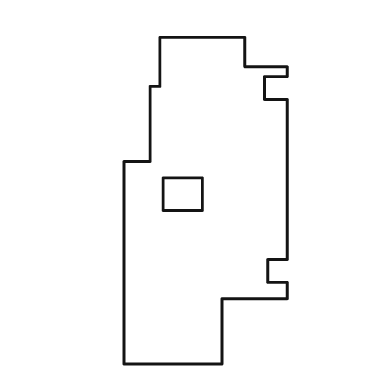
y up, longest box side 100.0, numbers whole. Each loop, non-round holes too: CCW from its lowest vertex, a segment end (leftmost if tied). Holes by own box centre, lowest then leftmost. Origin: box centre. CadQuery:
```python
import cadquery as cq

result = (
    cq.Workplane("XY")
    .moveTo(-25.0, -50.0)
    .lineTo(5.0, -50.0)
    .lineTo(5.0, -30.0)
    .lineTo(25.0, -30.0)
    .lineTo(25.0, -25.0)
    .lineTo(19.0, -25.0)
    .lineTo(19.0, -18.0)
    .lineTo(25.0, -18.0)
    .lineTo(25.0, 31.0)
    .lineTo(18.0, 31.0)
    .lineTo(18.0, 38.0)
    .lineTo(25.0, 38.0)
    .lineTo(25.0, 41.0)
    .lineTo(12.0, 41.0)
    .lineTo(12.0, 50.0)
    .lineTo(-14.0, 50.0)
    .lineTo(-14.0, 35.0)
    .lineTo(-17.0, 35.0)
    .lineTo(-17.0, 12.0)
    .lineTo(-25.0, 12.0)
    .close()
    .moveTo(-13.0, -3.0)
    .lineTo(-1.0, -3.0)
    .lineTo(-1.0, 7.0)
    .lineTo(-13.0, 7.0)
    .close()
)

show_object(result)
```